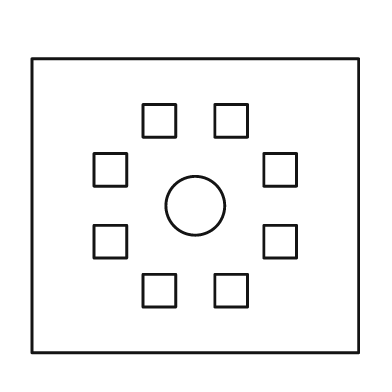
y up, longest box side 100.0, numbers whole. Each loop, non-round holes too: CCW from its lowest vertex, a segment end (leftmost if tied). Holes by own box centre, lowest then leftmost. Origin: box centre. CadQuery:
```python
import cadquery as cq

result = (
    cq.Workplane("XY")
    .moveTo(-50.0, -45.0)
    .lineTo(50.0, -45.0)
    .lineTo(50.0, 45.0)
    .lineTo(-50.0, 45.0)
    .close()
    .moveTo(-16.0, -31.0)
    .lineTo(-6.0, -31.0)
    .lineTo(-6.0, -21.0)
    .lineTo(-16.0, -21.0)
    .close()
    .moveTo(6.0, -31.0)
    .lineTo(16.0, -31.0)
    .lineTo(16.0, -21.0)
    .lineTo(6.0, -21.0)
    .close()
    .moveTo(-31.0, -16.0)
    .lineTo(-21.0, -16.0)
    .lineTo(-21.0, -6.0)
    .lineTo(-31.0, -6.0)
    .close()
    .moveTo(21.0, -16.0)
    .lineTo(31.0, -16.0)
    .lineTo(31.0, -6.0)
    .lineTo(21.0, -6.0)
    .close()
    .moveTo(0.0, 0.0)
    .circle(9.0)
    .moveTo(-31.0, 6.0)
    .lineTo(-21.0, 6.0)
    .lineTo(-21.0, 16.0)
    .lineTo(-31.0, 16.0)
    .close()
    .moveTo(21.0, 6.0)
    .lineTo(31.0, 6.0)
    .lineTo(31.0, 16.0)
    .lineTo(21.0, 16.0)
    .close()
    .moveTo(-16.0, 21.0)
    .lineTo(-6.0, 21.0)
    .lineTo(-6.0, 31.0)
    .lineTo(-16.0, 31.0)
    .close()
    .moveTo(6.0, 21.0)
    .lineTo(16.0, 21.0)
    .lineTo(16.0, 31.0)
    .lineTo(6.0, 31.0)
    .close()
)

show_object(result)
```